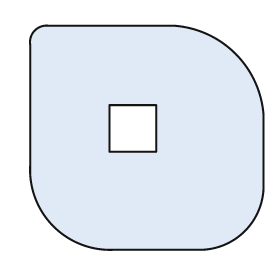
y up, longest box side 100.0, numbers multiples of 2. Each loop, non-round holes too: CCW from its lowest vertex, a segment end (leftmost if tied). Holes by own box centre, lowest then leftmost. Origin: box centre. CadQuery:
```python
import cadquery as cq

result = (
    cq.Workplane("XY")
    .moveTo(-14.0, -48.0)
    .lineTo(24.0, -48.0)
    .threePointArc((42.0, -40.0), (50.0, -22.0))
    .lineTo(50.0, 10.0)
    .threePointArc((38.0, 36.0), (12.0, 48.0))
    .lineTo(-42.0, 48.0)
    .threePointArc((-48.0, 46.0), (-50.0, 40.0))
    .lineTo(-50.0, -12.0)
    .threePointArc((-40.0, -38.0), (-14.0, -48.0))
    .close()
    .moveTo(-16.0, -6.0)
    .lineTo(4.0, -6.0)
    .lineTo(4.0, 14.0)
    .lineTo(-16.0, 14.0)
    .close()
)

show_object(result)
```